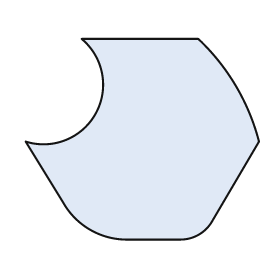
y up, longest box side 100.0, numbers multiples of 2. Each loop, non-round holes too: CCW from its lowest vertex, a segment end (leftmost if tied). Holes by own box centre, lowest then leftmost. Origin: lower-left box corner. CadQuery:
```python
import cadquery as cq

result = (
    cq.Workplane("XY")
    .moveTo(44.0, 0.0)
    .lineTo(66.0, 0.0)
    .threePointArc((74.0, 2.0), (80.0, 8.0))
    .lineTo(100.0, 42.0)
    .threePointArc((90.0, 66.0), (74.0, 86.0))
    .lineTo(24.0, 86.0)
    .threePointArc((30.0, 54.0), (0.0, 42.0))
    .lineTo(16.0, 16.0)
    .threePointArc((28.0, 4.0), (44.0, 0.0))
    .close()
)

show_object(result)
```